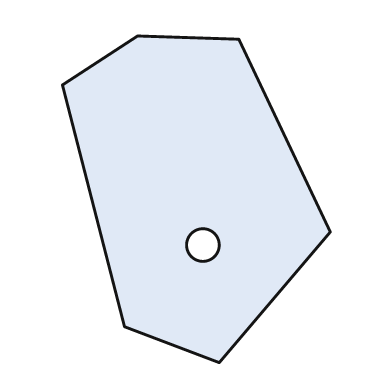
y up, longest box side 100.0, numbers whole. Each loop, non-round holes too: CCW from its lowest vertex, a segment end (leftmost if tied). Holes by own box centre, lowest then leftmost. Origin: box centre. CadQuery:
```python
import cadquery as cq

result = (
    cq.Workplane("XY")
    .moveTo(7.0, -50.0)
    .lineTo(41.0, -10.0)
    .lineTo(13.0, 49.0)
    .lineTo(-18.0, 50.0)
    .lineTo(-41.0, 35.0)
    .lineTo(-22.0, -39.0)
    .close()
    .moveTo(2.0, -14.0)
    .circle(5.0)
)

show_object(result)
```